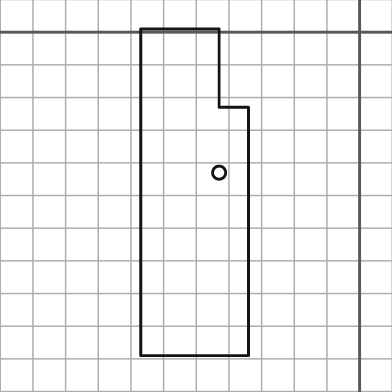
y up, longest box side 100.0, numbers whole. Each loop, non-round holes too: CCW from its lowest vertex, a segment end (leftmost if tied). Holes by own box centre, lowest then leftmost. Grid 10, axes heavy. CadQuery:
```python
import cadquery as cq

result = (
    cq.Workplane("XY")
    .moveTo(-67.0, -99.0)
    .lineTo(-34.0, -99.0)
    .lineTo(-34.0, -23.0)
    .lineTo(-43.0, -23.0)
    .lineTo(-43.0, 1.0)
    .lineTo(-67.0, 1.0)
    .close()
    .moveTo(-43.0, -43.0)
    .circle(2.0)
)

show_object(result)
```